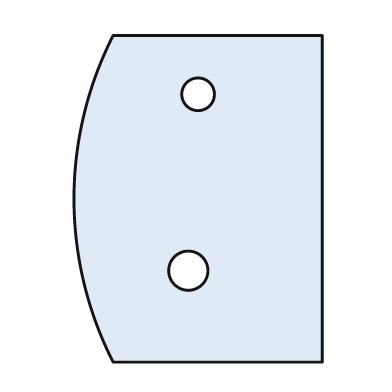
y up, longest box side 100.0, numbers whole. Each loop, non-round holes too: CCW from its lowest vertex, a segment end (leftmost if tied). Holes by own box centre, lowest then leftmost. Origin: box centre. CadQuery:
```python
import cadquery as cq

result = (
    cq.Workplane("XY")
    .moveTo(-26.0, -50.0)
    .lineTo(38.0, -50.0)
    .lineTo(38.0, 50.0)
    .lineTo(-26.0, 50.0)
    .threePointArc((-38.0, 0.0), (-26.0, -50.0))
    .close()
    .moveTo(-3.0, -22.0)
    .circle(6.0)
    .moveTo(0.0, 32.0)
    .circle(5.0)
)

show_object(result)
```